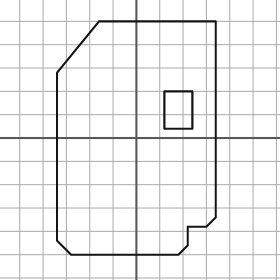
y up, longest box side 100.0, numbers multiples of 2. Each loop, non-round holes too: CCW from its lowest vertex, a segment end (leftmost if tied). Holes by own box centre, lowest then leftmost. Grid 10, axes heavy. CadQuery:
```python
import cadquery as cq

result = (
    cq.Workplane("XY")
    .moveTo(-28.0, -50.0)
    .lineTo(18.0, -50.0)
    .lineTo(22.0, -46.0)
    .lineTo(22.0, -38.0)
    .lineTo(30.0, -38.0)
    .lineTo(34.0, -34.0)
    .lineTo(34.0, 50.0)
    .lineTo(-16.0, 50.0)
    .lineTo(-34.0, 28.0)
    .lineTo(-34.0, -44.0)
    .close()
    .moveTo(12.0, 4.0)
    .lineTo(24.0, 4.0)
    .lineTo(24.0, 20.0)
    .lineTo(12.0, 20.0)
    .close()
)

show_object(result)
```